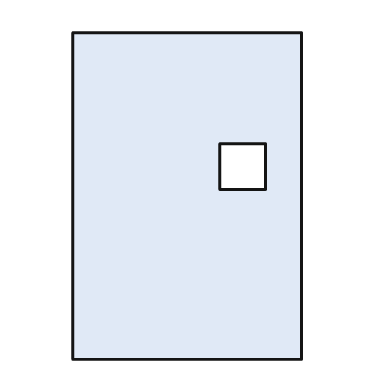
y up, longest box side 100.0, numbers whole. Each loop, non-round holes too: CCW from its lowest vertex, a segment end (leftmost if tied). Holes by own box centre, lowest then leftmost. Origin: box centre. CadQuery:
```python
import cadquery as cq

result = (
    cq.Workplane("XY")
    .moveTo(-35.0, -50.0)
    .lineTo(35.0, -50.0)
    .lineTo(35.0, 50.0)
    .lineTo(-35.0, 50.0)
    .close()
    .moveTo(10.0, 2.0)
    .lineTo(24.0, 2.0)
    .lineTo(24.0, 16.0)
    .lineTo(10.0, 16.0)
    .close()
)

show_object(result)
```